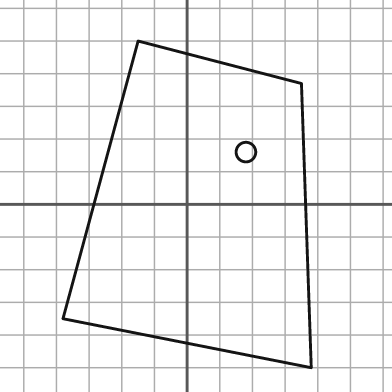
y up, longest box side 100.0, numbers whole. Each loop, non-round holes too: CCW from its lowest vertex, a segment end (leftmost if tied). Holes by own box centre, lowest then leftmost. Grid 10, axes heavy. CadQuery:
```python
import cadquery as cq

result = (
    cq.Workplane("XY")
    .moveTo(38.0, -50.0)
    .lineTo(35.0, 37.0)
    .lineTo(-15.0, 50.0)
    .lineTo(-38.0, -35.0)
    .close()
    .moveTo(18.0, 16.0)
    .circle(3.0)
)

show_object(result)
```